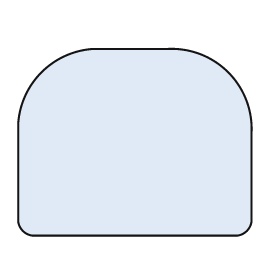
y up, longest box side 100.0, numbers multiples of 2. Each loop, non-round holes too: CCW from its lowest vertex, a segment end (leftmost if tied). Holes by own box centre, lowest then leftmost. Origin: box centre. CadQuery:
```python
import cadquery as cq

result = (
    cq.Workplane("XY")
    .moveTo(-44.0, -40.0)
    .lineTo(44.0, -40.0)
    .threePointArc((48.0, -38.0), (50.0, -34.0))
    .lineTo(50.0, 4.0)
    .threePointArc((40.0, 30.0), (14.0, 40.0))
    .lineTo(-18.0, 40.0)
    .threePointArc((-40.0, 30.0), (-50.0, 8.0))
    .lineTo(-50.0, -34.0)
    .threePointArc((-48.0, -38.0), (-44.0, -40.0))
    .close()
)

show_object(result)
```